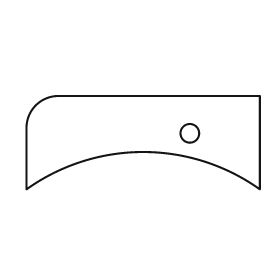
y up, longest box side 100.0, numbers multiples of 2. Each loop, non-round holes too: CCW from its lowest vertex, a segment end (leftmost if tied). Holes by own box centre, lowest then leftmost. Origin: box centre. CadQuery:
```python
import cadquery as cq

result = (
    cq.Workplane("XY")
    .moveTo(-50.0, -20.0)
    .threePointArc((0.0, -4.0), (50.0, -20.0))
    .lineTo(50.0, 20.0)
    .lineTo(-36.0, 20.0)
    .threePointArc((-46.0, 16.0), (-50.0, 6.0))
    .close()
    .moveTo(20.0, 4.0)
    .circle(4.0)
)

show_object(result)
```